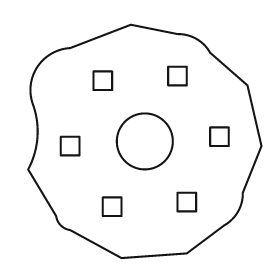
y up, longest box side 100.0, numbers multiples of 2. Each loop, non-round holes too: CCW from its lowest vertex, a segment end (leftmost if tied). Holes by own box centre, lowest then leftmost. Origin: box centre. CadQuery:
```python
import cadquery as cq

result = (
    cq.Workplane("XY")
    .moveTo(-10.0, -50.0)
    .lineTo(18.0, -48.0)
    .lineTo(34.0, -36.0)
    .threePointArc((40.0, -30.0), (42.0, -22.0))
    .lineTo(50.0, -2.0)
    .lineTo(44.0, 24.0)
    .lineTo(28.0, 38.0)
    .threePointArc((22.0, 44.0), (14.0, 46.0))
    .lineTo(-6.0, 50.0)
    .lineTo(-32.0, 40.0)
    .threePointArc((-46.0, 32.0), (-48.0, 16.0))
    .threePointArc((-46.0, 2.0), (-50.0, -12.0))
    .lineTo(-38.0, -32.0)
    .threePointArc((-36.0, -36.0), (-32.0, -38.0))
    .close()
    .moveTo(-18.0, -32.0)
    .lineTo(-10.0, -32.0)
    .lineTo(-10.0, -24.0)
    .lineTo(-18.0, -24.0)
    .close()
    .moveTo(14.0, -30.0)
    .lineTo(22.0, -30.0)
    .lineTo(22.0, -22.0)
    .lineTo(14.0, -22.0)
    .close()
    .moveTo(-36.0, -6.0)
    .lineTo(-28.0, -6.0)
    .lineTo(-28.0, 2.0)
    .lineTo(-36.0, 2.0)
    .close()
    .moveTo(0.0, 0.0)
    .circle(12.0)
    .moveTo(28.0, -2.0)
    .lineTo(36.0, -2.0)
    .lineTo(36.0, 6.0)
    .lineTo(28.0, 6.0)
    .close()
    .moveTo(-22.0, 22.0)
    .lineTo(-14.0, 22.0)
    .lineTo(-14.0, 30.0)
    .lineTo(-22.0, 30.0)
    .close()
    .moveTo(10.0, 24.0)
    .lineTo(18.0, 24.0)
    .lineTo(18.0, 32.0)
    .lineTo(10.0, 32.0)
    .close()
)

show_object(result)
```